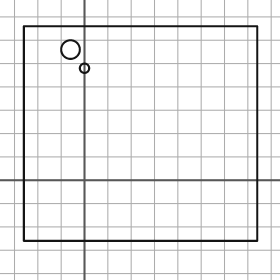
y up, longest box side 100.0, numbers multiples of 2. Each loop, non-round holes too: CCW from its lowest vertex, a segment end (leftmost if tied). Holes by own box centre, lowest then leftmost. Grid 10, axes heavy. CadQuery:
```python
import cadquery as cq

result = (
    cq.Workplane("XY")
    .moveTo(-26.0, -26.0)
    .lineTo(74.0, -26.0)
    .lineTo(74.0, 66.0)
    .lineTo(-26.0, 66.0)
    .close()
    .moveTo(0.0, 48.0)
    .circle(2.0)
    .moveTo(-6.0, 56.0)
    .circle(4.0)
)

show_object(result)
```